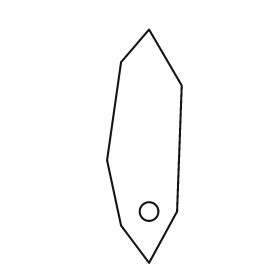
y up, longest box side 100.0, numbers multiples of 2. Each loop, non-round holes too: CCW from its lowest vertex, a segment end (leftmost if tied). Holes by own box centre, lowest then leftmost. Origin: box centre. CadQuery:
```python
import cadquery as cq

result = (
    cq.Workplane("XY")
    .moveTo(2.0, -50.0)
    .lineTo(14.0, -28.0)
    .lineTo(16.0, 26.0)
    .lineTo(2.0, 50.0)
    .lineTo(-10.0, 36.0)
    .lineTo(-16.0, -6.0)
    .lineTo(-10.0, -34.0)
    .close()
    .moveTo(2.0, -28.0)
    .circle(4.0)
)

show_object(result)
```